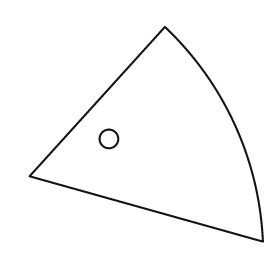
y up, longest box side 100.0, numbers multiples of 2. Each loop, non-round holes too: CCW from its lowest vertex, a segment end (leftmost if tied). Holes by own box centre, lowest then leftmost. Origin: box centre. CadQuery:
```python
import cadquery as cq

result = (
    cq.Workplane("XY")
    .moveTo(50.0, -46.0)
    .threePointArc((38.0, 4.0), (8.0, 46.0))
    .lineTo(-50.0, -18.0)
    .close()
    .moveTo(-16.0, -2.0)
    .circle(4.0)
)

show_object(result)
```